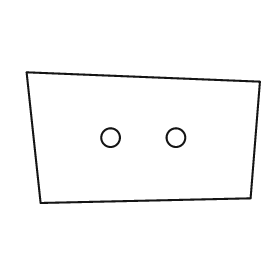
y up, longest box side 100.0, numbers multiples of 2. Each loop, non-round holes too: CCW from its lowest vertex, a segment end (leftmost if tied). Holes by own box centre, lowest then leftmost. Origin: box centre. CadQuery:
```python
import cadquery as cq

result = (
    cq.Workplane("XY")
    .moveTo(-44.0, -28.0)
    .lineTo(46.0, -26.0)
    .lineTo(50.0, 24.0)
    .lineTo(-50.0, 28.0)
    .close()
    .moveTo(-14.0, 0.0)
    .circle(4.0)
    .moveTo(14.0, 0.0)
    .circle(4.0)
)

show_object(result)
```